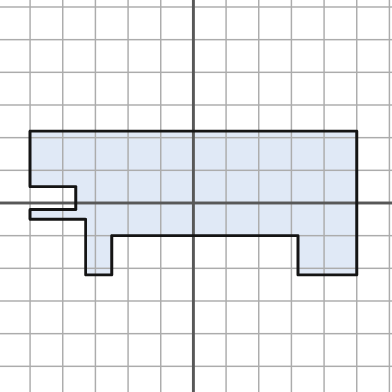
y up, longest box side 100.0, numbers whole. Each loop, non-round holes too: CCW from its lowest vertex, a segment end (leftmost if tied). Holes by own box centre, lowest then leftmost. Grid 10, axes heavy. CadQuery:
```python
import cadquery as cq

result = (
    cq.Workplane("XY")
    .moveTo(-33.0, -22.0)
    .lineTo(-25.0, -22.0)
    .lineTo(-25.0, -10.0)
    .lineTo(32.0, -10.0)
    .lineTo(32.0, -22.0)
    .lineTo(50.0, -22.0)
    .lineTo(50.0, 22.0)
    .lineTo(-50.0, 22.0)
    .lineTo(-50.0, 5.0)
    .lineTo(-36.0, 5.0)
    .lineTo(-36.0, -2.0)
    .lineTo(-50.0, -2.0)
    .lineTo(-50.0, -5.0)
    .lineTo(-33.0, -5.0)
    .close()
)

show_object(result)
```